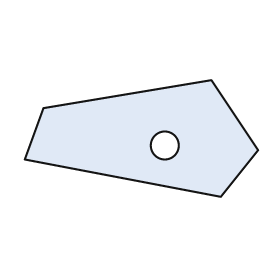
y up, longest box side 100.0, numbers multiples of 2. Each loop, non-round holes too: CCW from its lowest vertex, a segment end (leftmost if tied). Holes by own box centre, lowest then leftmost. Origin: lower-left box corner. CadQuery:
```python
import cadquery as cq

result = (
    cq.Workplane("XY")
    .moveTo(84.0, 0.0)
    .lineTo(100.0, 20.0)
    .lineTo(80.0, 50.0)
    .lineTo(8.0, 38.0)
    .lineTo(0.0, 16.0)
    .close()
    .moveTo(60.0, 22.0)
    .circle(6.0)
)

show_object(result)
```